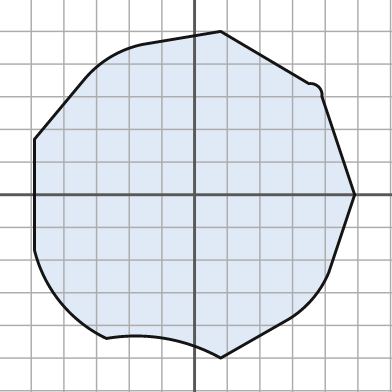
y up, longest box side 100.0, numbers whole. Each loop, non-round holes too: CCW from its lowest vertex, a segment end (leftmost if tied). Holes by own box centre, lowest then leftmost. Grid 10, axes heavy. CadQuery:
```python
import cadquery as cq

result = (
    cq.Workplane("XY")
    .moveTo(8.0, -50.0)
    .lineTo(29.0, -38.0)
    .threePointArc((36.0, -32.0), (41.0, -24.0))
    .lineTo(49.0, 0.0)
    .lineTo(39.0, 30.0)
    .threePointArc((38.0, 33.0), (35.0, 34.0))
    .lineTo(8.0, 50.0)
    .lineTo(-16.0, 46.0)
    .threePointArc((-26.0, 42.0), (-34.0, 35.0))
    .lineTo(-49.0, 17.0)
    .lineTo(-49.0, -17.0)
    .threePointArc((-41.0, -33.0), (-27.0, -44.0))
    .threePointArc((-9.0, -44.0), (8.0, -50.0))
    .close()
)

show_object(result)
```